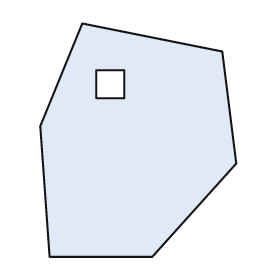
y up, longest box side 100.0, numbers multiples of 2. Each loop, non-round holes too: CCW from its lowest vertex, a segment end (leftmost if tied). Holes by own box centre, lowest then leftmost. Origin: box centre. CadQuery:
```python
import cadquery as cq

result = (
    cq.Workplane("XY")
    .moveTo(-38.0, -50.0)
    .lineTo(6.0, -50.0)
    .lineTo(42.0, -10.0)
    .lineTo(36.0, 38.0)
    .lineTo(-24.0, 50.0)
    .lineTo(-42.0, 6.0)
    .close()
    .moveTo(-18.0, 18.0)
    .lineTo(-6.0, 18.0)
    .lineTo(-6.0, 30.0)
    .lineTo(-18.0, 30.0)
    .close()
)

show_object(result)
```